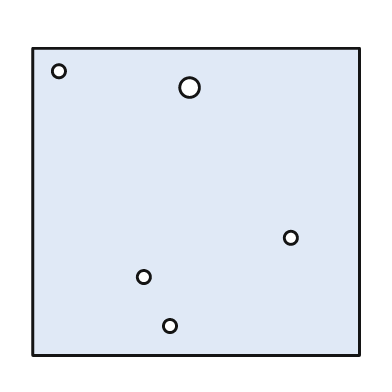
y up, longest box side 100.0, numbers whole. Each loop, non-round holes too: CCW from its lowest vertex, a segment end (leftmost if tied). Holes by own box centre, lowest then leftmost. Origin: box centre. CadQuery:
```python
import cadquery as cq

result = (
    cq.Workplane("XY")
    .moveTo(-50.0, -47.0)
    .lineTo(50.0, -47.0)
    .lineTo(50.0, 47.0)
    .lineTo(-50.0, 47.0)
    .close()
    .moveTo(-8.0, -38.0)
    .circle(2.0)
    .moveTo(-16.0, -23.0)
    .circle(2.0)
    .moveTo(29.0, -11.0)
    .circle(2.0)
    .moveTo(-2.0, 35.0)
    .circle(3.0)
    .moveTo(-42.0, 40.0)
    .circle(2.0)
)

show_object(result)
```